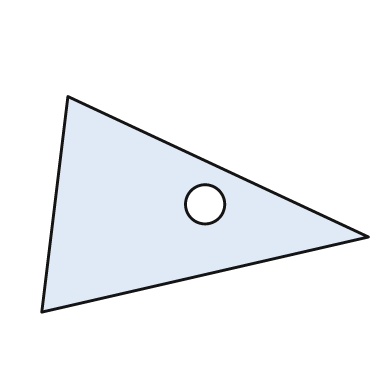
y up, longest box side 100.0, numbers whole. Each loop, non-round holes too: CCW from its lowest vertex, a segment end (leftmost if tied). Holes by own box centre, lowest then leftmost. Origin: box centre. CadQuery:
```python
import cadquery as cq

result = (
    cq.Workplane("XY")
    .moveTo(-50.0, -33.0)
    .lineTo(50.0, -10.0)
    .lineTo(-42.0, 33.0)
    .close()
    .moveTo(0.0, 0.0)
    .circle(6.0)
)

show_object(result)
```